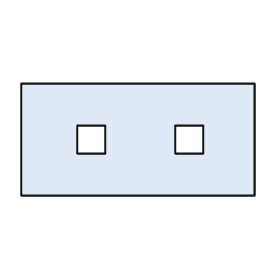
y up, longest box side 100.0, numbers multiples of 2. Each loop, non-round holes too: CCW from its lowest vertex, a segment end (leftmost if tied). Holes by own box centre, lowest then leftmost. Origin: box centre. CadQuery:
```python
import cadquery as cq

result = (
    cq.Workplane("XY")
    .moveTo(-50.0, -24.0)
    .lineTo(50.0, -24.0)
    .lineTo(50.0, 24.0)
    .lineTo(-50.0, 24.0)
    .close()
    .moveTo(-26.0, -6.0)
    .lineTo(-14.0, -6.0)
    .lineTo(-14.0, 6.0)
    .lineTo(-26.0, 6.0)
    .close()
    .moveTo(16.0, -6.0)
    .lineTo(28.0, -6.0)
    .lineTo(28.0, 6.0)
    .lineTo(16.0, 6.0)
    .close()
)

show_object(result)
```